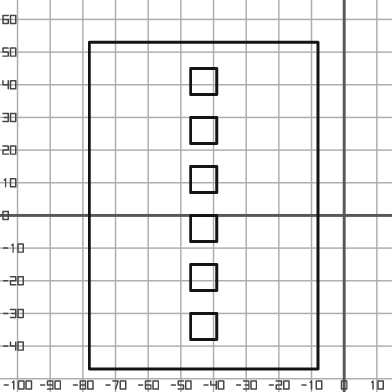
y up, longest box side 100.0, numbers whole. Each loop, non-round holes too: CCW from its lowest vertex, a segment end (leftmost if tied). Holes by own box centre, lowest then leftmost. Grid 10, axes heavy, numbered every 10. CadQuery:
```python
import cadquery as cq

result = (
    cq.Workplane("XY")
    .moveTo(-78.0, -47.0)
    .lineTo(-8.0, -47.0)
    .lineTo(-8.0, 53.0)
    .lineTo(-78.0, 53.0)
    .close()
    .moveTo(-47.0, -38.0)
    .lineTo(-39.0, -38.0)
    .lineTo(-39.0, -30.0)
    .lineTo(-47.0, -30.0)
    .close()
    .moveTo(-47.0, -23.0)
    .lineTo(-39.0, -23.0)
    .lineTo(-39.0, -15.0)
    .lineTo(-47.0, -15.0)
    .close()
    .moveTo(-47.0, -8.0)
    .lineTo(-39.0, -8.0)
    .lineTo(-39.0, 0.0)
    .lineTo(-47.0, 0.0)
    .close()
    .moveTo(-47.0, 7.0)
    .lineTo(-39.0, 7.0)
    .lineTo(-39.0, 15.0)
    .lineTo(-47.0, 15.0)
    .close()
    .moveTo(-47.0, 22.0)
    .lineTo(-39.0, 22.0)
    .lineTo(-39.0, 30.0)
    .lineTo(-47.0, 30.0)
    .close()
    .moveTo(-47.0, 37.0)
    .lineTo(-39.0, 37.0)
    .lineTo(-39.0, 45.0)
    .lineTo(-47.0, 45.0)
    .close()
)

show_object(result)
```